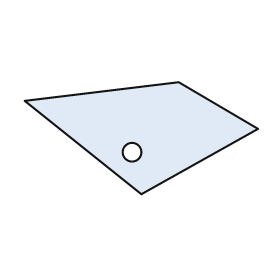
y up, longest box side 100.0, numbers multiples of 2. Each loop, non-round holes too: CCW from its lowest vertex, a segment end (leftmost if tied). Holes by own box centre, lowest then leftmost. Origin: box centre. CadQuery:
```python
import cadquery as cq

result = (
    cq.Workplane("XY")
    .moveTo(0.0, -24.0)
    .lineTo(50.0, 4.0)
    .lineTo(16.0, 24.0)
    .lineTo(-50.0, 16.0)
    .close()
    .moveTo(-4.0, -6.0)
    .circle(4.0)
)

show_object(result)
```